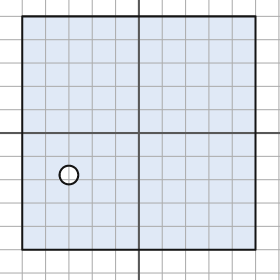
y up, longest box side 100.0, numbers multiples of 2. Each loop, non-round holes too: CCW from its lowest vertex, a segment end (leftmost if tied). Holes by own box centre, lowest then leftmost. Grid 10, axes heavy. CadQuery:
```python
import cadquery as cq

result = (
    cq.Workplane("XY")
    .moveTo(-50.0, -50.0)
    .lineTo(50.0, -50.0)
    .lineTo(50.0, 50.0)
    .lineTo(-50.0, 50.0)
    .close()
    .moveTo(-30.0, -18.0)
    .circle(4.0)
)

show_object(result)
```